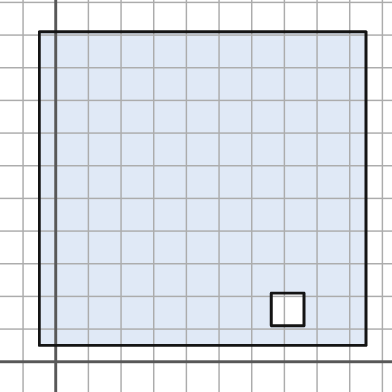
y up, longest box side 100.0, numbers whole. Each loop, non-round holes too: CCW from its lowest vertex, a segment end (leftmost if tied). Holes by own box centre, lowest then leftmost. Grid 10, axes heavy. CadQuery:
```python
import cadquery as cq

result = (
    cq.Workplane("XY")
    .moveTo(-5.0, 5.0)
    .lineTo(95.0, 5.0)
    .lineTo(95.0, 101.0)
    .lineTo(-5.0, 101.0)
    .close()
    .moveTo(66.0, 11.0)
    .lineTo(76.0, 11.0)
    .lineTo(76.0, 21.0)
    .lineTo(66.0, 21.0)
    .close()
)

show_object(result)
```